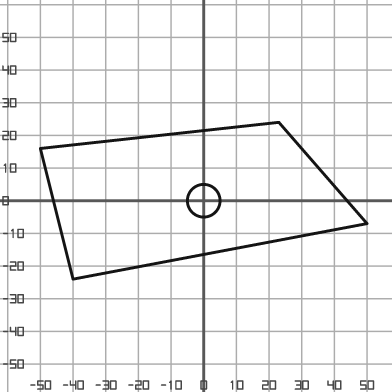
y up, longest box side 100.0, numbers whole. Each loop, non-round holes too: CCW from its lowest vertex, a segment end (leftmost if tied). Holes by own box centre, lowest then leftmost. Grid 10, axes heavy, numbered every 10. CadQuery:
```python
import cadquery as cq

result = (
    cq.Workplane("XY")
    .moveTo(-40.0, -24.0)
    .lineTo(50.0, -7.0)
    .lineTo(23.0, 24.0)
    .lineTo(-50.0, 16.0)
    .close()
    .moveTo(0.0, 0.0)
    .circle(5.0)
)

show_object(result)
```